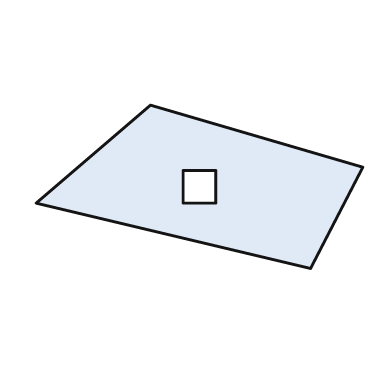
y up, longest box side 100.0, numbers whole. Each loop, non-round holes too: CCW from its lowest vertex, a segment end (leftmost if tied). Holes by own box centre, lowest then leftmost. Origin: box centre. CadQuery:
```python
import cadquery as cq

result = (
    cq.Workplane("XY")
    .moveTo(34.0, -25.0)
    .lineTo(50.0, 6.0)
    .lineTo(-15.0, 25.0)
    .lineTo(-50.0, -5.0)
    .close()
    .moveTo(-5.0, -5.0)
    .lineTo(5.0, -5.0)
    .lineTo(5.0, 5.0)
    .lineTo(-5.0, 5.0)
    .close()
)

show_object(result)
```